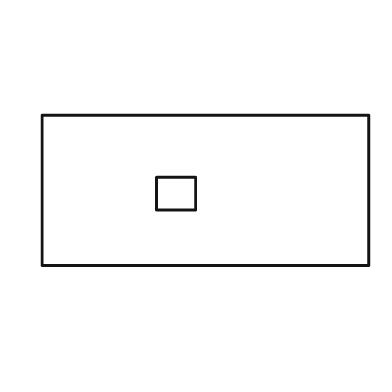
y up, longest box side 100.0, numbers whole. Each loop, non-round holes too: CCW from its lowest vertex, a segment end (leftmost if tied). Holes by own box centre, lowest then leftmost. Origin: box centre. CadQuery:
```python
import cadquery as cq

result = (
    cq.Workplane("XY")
    .moveTo(-50.0, -23.0)
    .lineTo(50.0, -23.0)
    .lineTo(50.0, 23.0)
    .lineTo(-50.0, 23.0)
    .close()
    .moveTo(-15.0, -6.0)
    .lineTo(-3.0, -6.0)
    .lineTo(-3.0, 4.0)
    .lineTo(-15.0, 4.0)
    .close()
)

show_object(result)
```